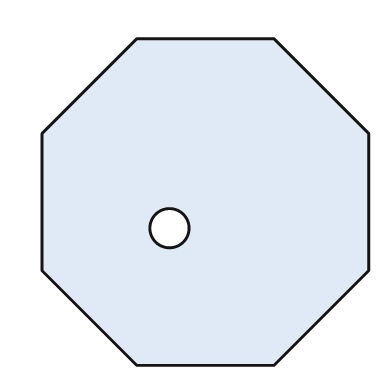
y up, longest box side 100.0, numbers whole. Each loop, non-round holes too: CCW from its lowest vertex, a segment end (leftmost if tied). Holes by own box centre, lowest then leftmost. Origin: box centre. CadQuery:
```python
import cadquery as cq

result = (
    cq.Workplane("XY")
    .moveTo(-21.0, -50.0)
    .lineTo(21.0, -50.0)
    .lineTo(50.0, -21.0)
    .lineTo(50.0, 21.0)
    .lineTo(21.0, 50.0)
    .lineTo(-21.0, 50.0)
    .lineTo(-50.0, 21.0)
    .lineTo(-50.0, -21.0)
    .close()
    .moveTo(-11.0, -8.0)
    .circle(6.0)
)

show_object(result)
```